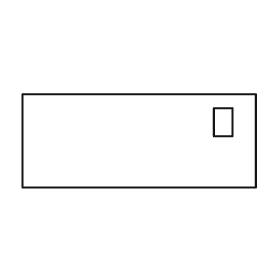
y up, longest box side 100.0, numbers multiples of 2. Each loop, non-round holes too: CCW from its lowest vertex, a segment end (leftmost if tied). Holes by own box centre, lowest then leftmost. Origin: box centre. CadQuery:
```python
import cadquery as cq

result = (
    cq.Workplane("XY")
    .moveTo(-50.0, -20.0)
    .lineTo(50.0, -20.0)
    .lineTo(50.0, 20.0)
    .lineTo(-50.0, 20.0)
    .close()
    .moveTo(32.0, 2.0)
    .lineTo(40.0, 2.0)
    .lineTo(40.0, 14.0)
    .lineTo(32.0, 14.0)
    .close()
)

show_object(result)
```